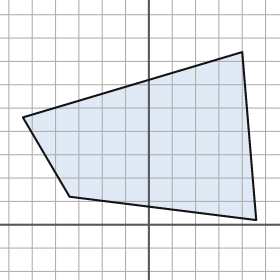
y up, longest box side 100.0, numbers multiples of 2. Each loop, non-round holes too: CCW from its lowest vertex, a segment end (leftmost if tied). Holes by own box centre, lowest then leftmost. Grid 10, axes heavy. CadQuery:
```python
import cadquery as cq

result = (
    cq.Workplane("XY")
    .moveTo(46.0, 2.0)
    .lineTo(40.0, 74.0)
    .lineTo(-54.0, 46.0)
    .lineTo(-34.0, 12.0)
    .close()
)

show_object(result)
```